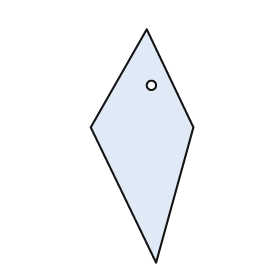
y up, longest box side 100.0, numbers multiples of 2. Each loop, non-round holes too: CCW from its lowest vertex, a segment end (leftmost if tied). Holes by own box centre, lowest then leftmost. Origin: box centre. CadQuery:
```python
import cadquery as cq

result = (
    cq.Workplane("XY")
    .moveTo(6.0, -50.0)
    .lineTo(22.0, 8.0)
    .lineTo(2.0, 50.0)
    .lineTo(-22.0, 8.0)
    .close()
    .moveTo(4.0, 26.0)
    .circle(2.0)
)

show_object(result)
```